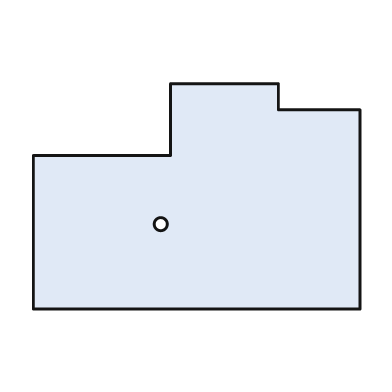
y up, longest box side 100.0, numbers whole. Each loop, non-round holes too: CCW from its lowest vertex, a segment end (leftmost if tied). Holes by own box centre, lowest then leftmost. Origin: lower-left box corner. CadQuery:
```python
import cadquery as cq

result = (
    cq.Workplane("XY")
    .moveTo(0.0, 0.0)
    .lineTo(100.0, 0.0)
    .lineTo(100.0, 61.0)
    .lineTo(75.0, 61.0)
    .lineTo(75.0, 69.0)
    .lineTo(42.0, 69.0)
    .lineTo(42.0, 47.0)
    .lineTo(0.0, 47.0)
    .close()
    .moveTo(39.0, 26.0)
    .circle(2.0)
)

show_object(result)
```